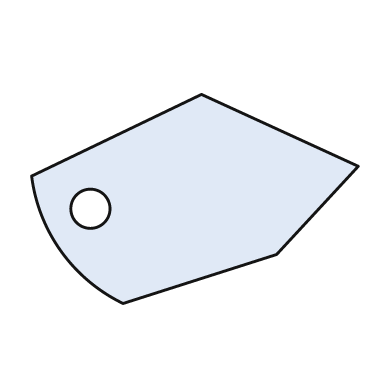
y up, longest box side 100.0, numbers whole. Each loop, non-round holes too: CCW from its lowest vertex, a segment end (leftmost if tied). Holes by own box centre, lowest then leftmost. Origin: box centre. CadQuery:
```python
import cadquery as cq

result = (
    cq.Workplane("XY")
    .moveTo(-22.0, -32.0)
    .lineTo(25.0, -17.0)
    .lineTo(50.0, 10.0)
    .lineTo(2.0, 32.0)
    .lineTo(-50.0, 7.0)
    .threePointArc((-41.0, -16.0), (-22.0, -32.0))
    .close()
    .moveTo(-32.0, -3.0)
    .circle(6.0)
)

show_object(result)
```